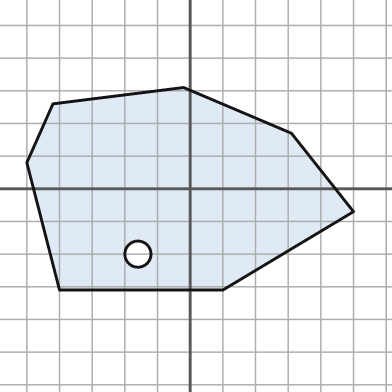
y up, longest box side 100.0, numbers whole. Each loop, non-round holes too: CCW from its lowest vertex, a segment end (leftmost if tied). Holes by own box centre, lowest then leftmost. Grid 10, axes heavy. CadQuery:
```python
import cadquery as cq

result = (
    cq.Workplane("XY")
    .moveTo(-40.0, -31.0)
    .lineTo(10.0, -31.0)
    .lineTo(50.0, -7.0)
    .lineTo(31.0, 17.0)
    .lineTo(-2.0, 31.0)
    .lineTo(-42.0, 26.0)
    .lineTo(-50.0, 8.0)
    .close()
    .moveTo(-16.0, -20.0)
    .circle(4.0)
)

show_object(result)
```